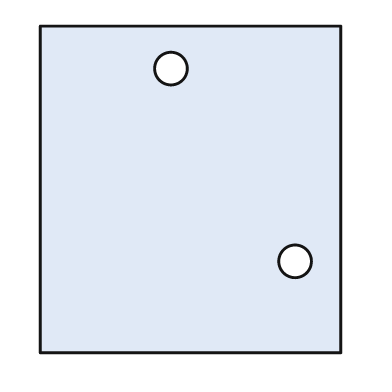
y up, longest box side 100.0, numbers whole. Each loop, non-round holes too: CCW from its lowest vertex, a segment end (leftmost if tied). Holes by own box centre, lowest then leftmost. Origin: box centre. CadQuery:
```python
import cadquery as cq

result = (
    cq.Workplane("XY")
    .moveTo(-46.0, -50.0)
    .lineTo(46.0, -50.0)
    .lineTo(46.0, 50.0)
    .lineTo(-46.0, 50.0)
    .close()
    .moveTo(32.0, -22.0)
    .circle(5.0)
    .moveTo(-6.0, 37.0)
    .circle(5.0)
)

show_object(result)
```